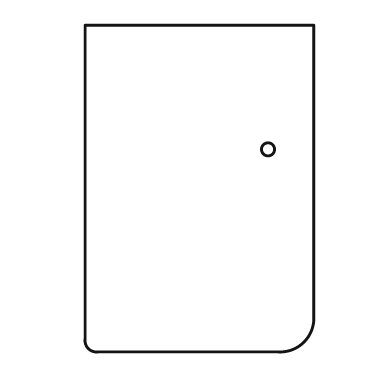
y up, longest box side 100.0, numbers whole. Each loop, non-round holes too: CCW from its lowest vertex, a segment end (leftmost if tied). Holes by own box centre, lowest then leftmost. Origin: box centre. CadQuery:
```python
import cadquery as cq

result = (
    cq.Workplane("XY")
    .moveTo(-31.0, -50.0)
    .lineTo(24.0, -50.0)
    .threePointArc((32.0, -47.0), (35.0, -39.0))
    .lineTo(35.0, 50.0)
    .lineTo(-35.0, 50.0)
    .lineTo(-35.0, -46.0)
    .threePointArc((-34.0, -49.0), (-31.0, -50.0))
    .close()
    .moveTo(21.0, 12.0)
    .circle(2.0)
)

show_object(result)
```